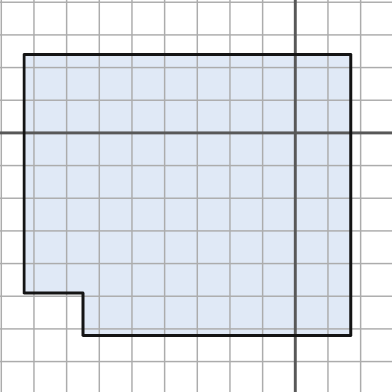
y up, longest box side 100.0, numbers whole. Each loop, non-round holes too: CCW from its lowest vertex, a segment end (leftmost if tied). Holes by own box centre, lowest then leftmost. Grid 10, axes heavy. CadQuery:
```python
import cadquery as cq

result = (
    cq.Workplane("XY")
    .moveTo(-65.0, -62.0)
    .lineTo(17.0, -62.0)
    .lineTo(17.0, 24.0)
    .lineTo(-83.0, 24.0)
    .lineTo(-83.0, -49.0)
    .lineTo(-65.0, -49.0)
    .close()
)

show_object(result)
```